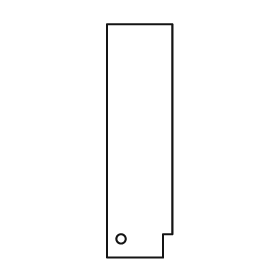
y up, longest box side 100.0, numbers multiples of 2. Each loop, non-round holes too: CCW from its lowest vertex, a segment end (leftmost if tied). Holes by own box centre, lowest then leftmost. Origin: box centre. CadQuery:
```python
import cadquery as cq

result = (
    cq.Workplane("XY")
    .moveTo(-14.0, -50.0)
    .lineTo(10.0, -50.0)
    .lineTo(10.0, -40.0)
    .lineTo(14.0, -40.0)
    .lineTo(14.0, 50.0)
    .lineTo(-14.0, 50.0)
    .close()
    .moveTo(-8.0, -42.0)
    .circle(2.0)
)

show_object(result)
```